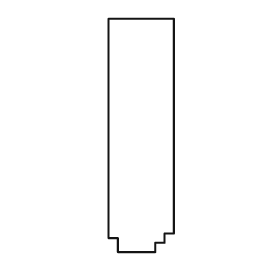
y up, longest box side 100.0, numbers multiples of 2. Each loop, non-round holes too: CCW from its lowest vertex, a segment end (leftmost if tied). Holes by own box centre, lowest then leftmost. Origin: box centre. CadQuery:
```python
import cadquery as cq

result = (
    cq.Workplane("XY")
    .moveTo(-10.0, -50.0)
    .lineTo(6.0, -50.0)
    .lineTo(6.0, -46.0)
    .lineTo(10.0, -46.0)
    .lineTo(10.0, -42.0)
    .lineTo(14.0, -42.0)
    .lineTo(14.0, 50.0)
    .lineTo(-14.0, 50.0)
    .lineTo(-14.0, -44.0)
    .lineTo(-10.0, -44.0)
    .close()
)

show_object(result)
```